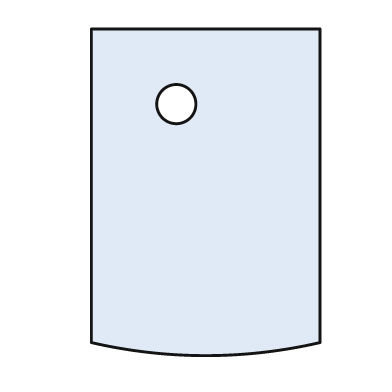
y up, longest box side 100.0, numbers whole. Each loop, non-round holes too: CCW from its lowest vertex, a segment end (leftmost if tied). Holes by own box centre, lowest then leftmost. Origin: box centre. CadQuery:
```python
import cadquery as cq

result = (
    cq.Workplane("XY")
    .moveTo(-35.0, -46.0)
    .threePointArc((0.0, -50.0), (35.0, -46.0))
    .lineTo(35.0, 50.0)
    .lineTo(-35.0, 50.0)
    .close()
    .moveTo(-9.0, 27.0)
    .circle(6.0)
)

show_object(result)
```